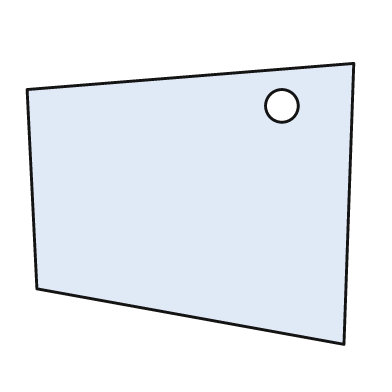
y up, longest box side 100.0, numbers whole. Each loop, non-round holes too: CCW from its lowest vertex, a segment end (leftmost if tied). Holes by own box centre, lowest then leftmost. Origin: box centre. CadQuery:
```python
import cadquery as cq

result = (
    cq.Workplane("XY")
    .moveTo(47.0, -43.0)
    .lineTo(50.0, 43.0)
    .lineTo(-50.0, 35.0)
    .lineTo(-47.0, -26.0)
    .close()
    .moveTo(28.0, 30.0)
    .circle(5.0)
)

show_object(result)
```